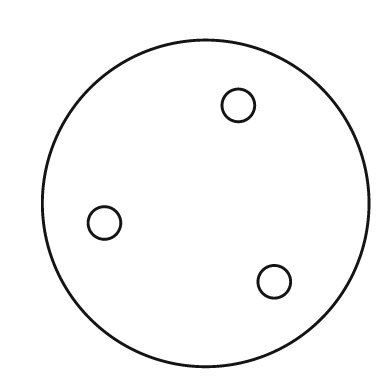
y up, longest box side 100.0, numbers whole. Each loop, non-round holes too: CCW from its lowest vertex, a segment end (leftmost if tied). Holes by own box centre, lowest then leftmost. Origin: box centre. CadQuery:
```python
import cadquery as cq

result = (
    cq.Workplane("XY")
    .moveTo(0.0, 0.0)
    .circle(50.0)
    .moveTo(21.0, -24.0)
    .circle(5.0)
    .moveTo(-31.0, -6.0)
    .circle(5.0)
    .moveTo(10.0, 30.0)
    .circle(5.0)
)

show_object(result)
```